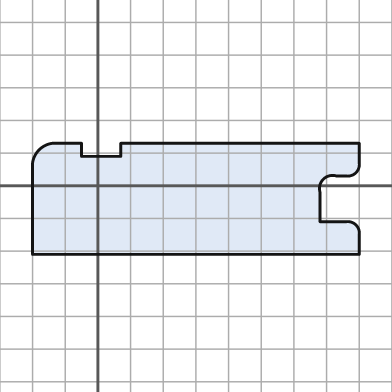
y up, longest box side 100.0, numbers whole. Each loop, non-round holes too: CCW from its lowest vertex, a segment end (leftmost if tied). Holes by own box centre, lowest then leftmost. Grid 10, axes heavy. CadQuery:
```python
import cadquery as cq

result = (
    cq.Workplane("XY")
    .moveTo(-20.0, -21.0)
    .lineTo(80.0, -21.0)
    .lineTo(80.0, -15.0)
    .threePointArc((79.0, -12.0), (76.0, -11.0))
    .lineTo(68.0, -11.0)
    .lineTo(68.0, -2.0)
    .threePointArc((69.0, 2.0), (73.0, 3.0))
    .lineTo(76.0, 3.0)
    .threePointArc((79.0, 4.0), (80.0, 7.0))
    .lineTo(80.0, 13.0)
    .lineTo(7.0, 13.0)
    .lineTo(7.0, 9.0)
    .lineTo(-5.0, 9.0)
    .lineTo(-5.0, 13.0)
    .lineTo(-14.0, 13.0)
    .threePointArc((-18.0, 11.0), (-20.0, 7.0))
    .close()
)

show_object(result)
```